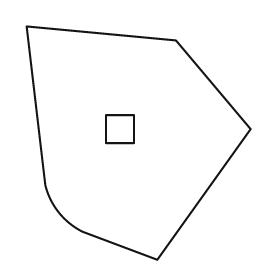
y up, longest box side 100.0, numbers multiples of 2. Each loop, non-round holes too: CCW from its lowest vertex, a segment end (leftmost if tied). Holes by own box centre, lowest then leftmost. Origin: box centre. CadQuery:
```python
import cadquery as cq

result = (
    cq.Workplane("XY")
    .moveTo(8.0, -50.0)
    .lineTo(48.0, 6.0)
    .lineTo(16.0, 44.0)
    .lineTo(-48.0, 50.0)
    .lineTo(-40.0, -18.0)
    .threePointArc((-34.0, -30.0), (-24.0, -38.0))
    .close()
    .moveTo(-14.0, 0.0)
    .lineTo(-2.0, 0.0)
    .lineTo(-2.0, 12.0)
    .lineTo(-14.0, 12.0)
    .close()
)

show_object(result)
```